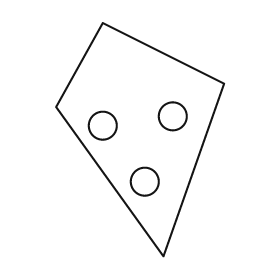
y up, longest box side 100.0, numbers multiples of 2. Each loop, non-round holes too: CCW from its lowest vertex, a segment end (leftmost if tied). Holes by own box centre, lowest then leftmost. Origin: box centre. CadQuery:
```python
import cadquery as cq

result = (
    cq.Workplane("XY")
    .moveTo(10.0, -50.0)
    .lineTo(36.0, 24.0)
    .lineTo(-16.0, 50.0)
    .lineTo(-36.0, 14.0)
    .close()
    .moveTo(2.0, -18.0)
    .circle(6.0)
    .moveTo(-16.0, 6.0)
    .circle(6.0)
    .moveTo(14.0, 10.0)
    .circle(6.0)
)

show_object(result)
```